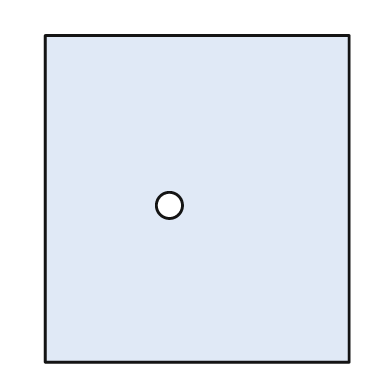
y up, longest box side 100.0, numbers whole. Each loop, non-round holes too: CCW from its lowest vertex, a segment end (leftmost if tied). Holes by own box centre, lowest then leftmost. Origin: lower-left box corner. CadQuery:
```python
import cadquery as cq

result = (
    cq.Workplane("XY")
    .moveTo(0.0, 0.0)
    .lineTo(93.0, 0.0)
    .lineTo(93.0, 100.0)
    .lineTo(0.0, 100.0)
    .close()
    .moveTo(38.0, 48.0)
    .circle(4.0)
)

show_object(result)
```